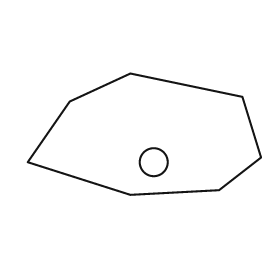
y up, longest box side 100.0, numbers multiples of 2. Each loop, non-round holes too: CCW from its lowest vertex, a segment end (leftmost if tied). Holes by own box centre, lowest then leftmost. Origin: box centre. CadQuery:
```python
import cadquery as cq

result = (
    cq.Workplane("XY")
    .moveTo(-6.0, -26.0)
    .lineTo(32.0, -24.0)
    .lineTo(50.0, -10.0)
    .lineTo(42.0, 16.0)
    .lineTo(-6.0, 26.0)
    .lineTo(-32.0, 14.0)
    .lineTo(-50.0, -12.0)
    .close()
    .moveTo(4.0, -12.0)
    .circle(6.0)
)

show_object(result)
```